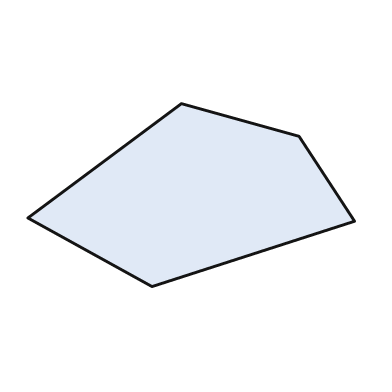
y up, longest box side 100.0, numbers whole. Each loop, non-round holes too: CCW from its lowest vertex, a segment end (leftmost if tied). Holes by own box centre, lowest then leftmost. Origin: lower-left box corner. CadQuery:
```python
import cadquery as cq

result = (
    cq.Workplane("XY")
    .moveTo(38.0, 0.0)
    .lineTo(100.0, 20.0)
    .lineTo(83.0, 46.0)
    .lineTo(47.0, 56.0)
    .lineTo(0.0, 21.0)
    .close()
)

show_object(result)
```